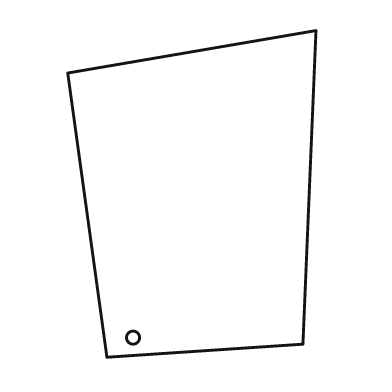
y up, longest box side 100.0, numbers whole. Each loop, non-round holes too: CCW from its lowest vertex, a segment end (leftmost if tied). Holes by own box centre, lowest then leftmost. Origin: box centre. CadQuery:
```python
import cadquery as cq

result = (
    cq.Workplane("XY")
    .moveTo(-26.0, -50.0)
    .lineTo(34.0, -46.0)
    .lineTo(38.0, 50.0)
    .lineTo(-38.0, 37.0)
    .close()
    .moveTo(-18.0, -44.0)
    .circle(2.0)
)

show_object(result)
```